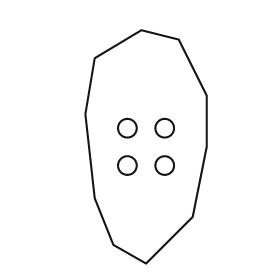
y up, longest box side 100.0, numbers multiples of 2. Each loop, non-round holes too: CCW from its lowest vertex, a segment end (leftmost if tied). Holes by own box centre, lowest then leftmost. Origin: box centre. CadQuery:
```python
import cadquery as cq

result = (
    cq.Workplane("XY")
    .moveTo(0.0, -50.0)
    .lineTo(20.0, -30.0)
    .lineTo(26.0, 0.0)
    .lineTo(26.0, 22.0)
    .lineTo(14.0, 46.0)
    .lineTo(-2.0, 50.0)
    .lineTo(-22.0, 38.0)
    .lineTo(-26.0, 14.0)
    .lineTo(-22.0, -22.0)
    .lineTo(-14.0, -42.0)
    .close()
    .moveTo(-8.0, -8.0)
    .circle(4.0)
    .moveTo(8.0, -8.0)
    .circle(4.0)
    .moveTo(-8.0, 8.0)
    .circle(4.0)
    .moveTo(8.0, 8.0)
    .circle(4.0)
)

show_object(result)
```